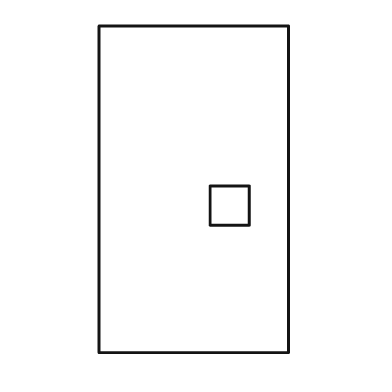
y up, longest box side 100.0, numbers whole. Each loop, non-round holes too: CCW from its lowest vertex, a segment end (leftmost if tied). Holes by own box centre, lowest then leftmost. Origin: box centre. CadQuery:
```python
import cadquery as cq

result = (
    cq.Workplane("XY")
    .moveTo(-29.0, -50.0)
    .lineTo(29.0, -50.0)
    .lineTo(29.0, 50.0)
    .lineTo(-29.0, 50.0)
    .close()
    .moveTo(5.0, -11.0)
    .lineTo(17.0, -11.0)
    .lineTo(17.0, 1.0)
    .lineTo(5.0, 1.0)
    .close()
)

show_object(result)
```